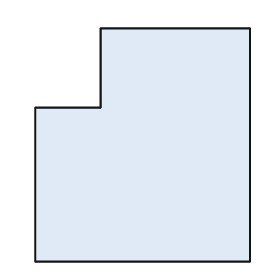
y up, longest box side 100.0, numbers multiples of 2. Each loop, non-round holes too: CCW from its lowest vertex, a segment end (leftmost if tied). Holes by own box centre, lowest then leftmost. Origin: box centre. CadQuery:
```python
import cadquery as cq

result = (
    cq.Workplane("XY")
    .moveTo(-46.0, -50.0)
    .lineTo(46.0, -50.0)
    .lineTo(46.0, 50.0)
    .lineTo(-18.0, 50.0)
    .lineTo(-18.0, 16.0)
    .lineTo(-46.0, 16.0)
    .close()
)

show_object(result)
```